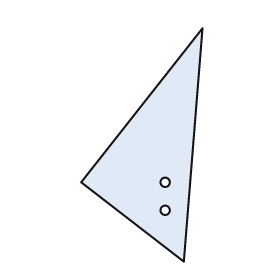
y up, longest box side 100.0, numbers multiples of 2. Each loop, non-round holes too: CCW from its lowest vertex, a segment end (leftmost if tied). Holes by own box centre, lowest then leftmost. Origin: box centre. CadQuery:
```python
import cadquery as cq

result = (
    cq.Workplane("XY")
    .moveTo(18.0, -50.0)
    .lineTo(26.0, 50.0)
    .lineTo(-26.0, -16.0)
    .close()
    .moveTo(10.0, -28.0)
    .circle(2.0)
    .moveTo(10.0, -16.0)
    .circle(2.0)
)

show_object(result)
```